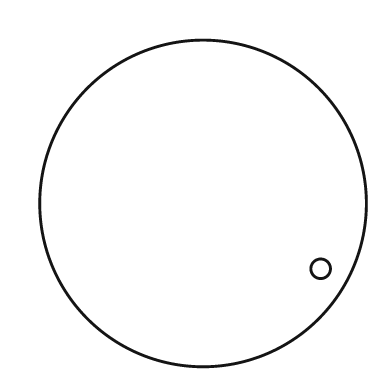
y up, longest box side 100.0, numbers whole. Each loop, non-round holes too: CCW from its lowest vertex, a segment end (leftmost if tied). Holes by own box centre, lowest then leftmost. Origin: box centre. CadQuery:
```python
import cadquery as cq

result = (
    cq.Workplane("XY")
    .moveTo(0.0, 0.0)
    .circle(50.0)
    .moveTo(36.0, -20.0)
    .circle(3.0)
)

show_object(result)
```